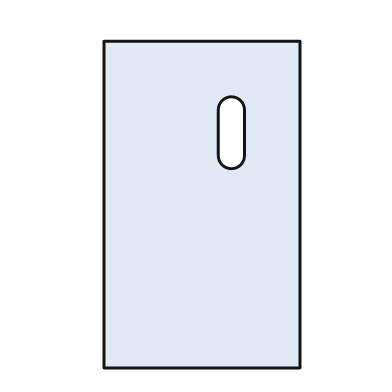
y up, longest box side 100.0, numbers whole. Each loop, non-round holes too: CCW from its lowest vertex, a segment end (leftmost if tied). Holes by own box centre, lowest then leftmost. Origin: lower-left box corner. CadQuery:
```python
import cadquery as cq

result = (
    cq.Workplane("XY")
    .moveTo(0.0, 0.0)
    .lineTo(60.0, 0.0)
    .lineTo(60.0, 100.0)
    .lineTo(0.0, 100.0)
    .close()
    .moveTo(35.0, 65.0)
    .threePointArc((39.0, 61.0), (43.0, 65.0))
    .lineTo(43.0, 79.0)
    .threePointArc((39.0, 83.0), (35.0, 79.0))
    .close()
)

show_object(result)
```